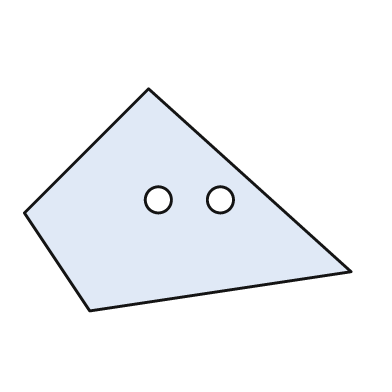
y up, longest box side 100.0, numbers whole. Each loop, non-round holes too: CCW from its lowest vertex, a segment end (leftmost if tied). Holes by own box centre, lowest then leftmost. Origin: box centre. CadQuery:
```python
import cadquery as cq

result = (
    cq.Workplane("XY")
    .moveTo(-30.0, -34.0)
    .lineTo(50.0, -22.0)
    .lineTo(-12.0, 34.0)
    .lineTo(-50.0, -4.0)
    .close()
    .moveTo(-9.0, 0.0)
    .circle(4.0)
    .moveTo(10.0, 0.0)
    .circle(4.0)
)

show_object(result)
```